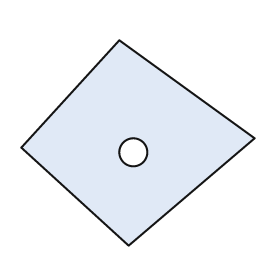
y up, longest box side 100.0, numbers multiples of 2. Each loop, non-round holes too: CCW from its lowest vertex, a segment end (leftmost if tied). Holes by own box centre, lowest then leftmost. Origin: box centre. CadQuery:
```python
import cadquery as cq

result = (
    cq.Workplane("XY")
    .moveTo(-4.0, -44.0)
    .lineTo(50.0, 2.0)
    .lineTo(-8.0, 44.0)
    .lineTo(-50.0, -2.0)
    .close()
    .moveTo(-2.0, -4.0)
    .circle(6.0)
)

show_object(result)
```